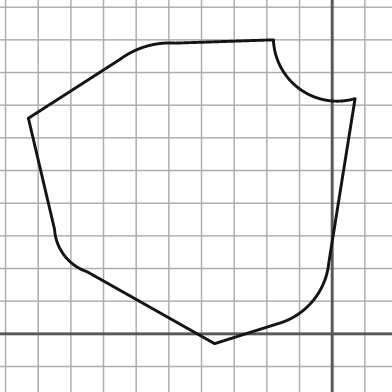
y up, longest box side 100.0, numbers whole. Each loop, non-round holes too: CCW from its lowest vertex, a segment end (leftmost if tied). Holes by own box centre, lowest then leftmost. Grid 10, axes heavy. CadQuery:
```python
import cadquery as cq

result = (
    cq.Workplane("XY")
    .moveTo(-36.0, -3.0)
    .lineTo(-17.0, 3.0)
    .threePointArc((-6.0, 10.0), (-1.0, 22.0))
    .lineTo(7.0, 72.0)
    .threePointArc((-10.0, 75.0), (-18.0, 90.0))
    .lineTo(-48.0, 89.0)
    .threePointArc((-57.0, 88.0), (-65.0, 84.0))
    .lineTo(-93.0, 66.0)
    .lineTo(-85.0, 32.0)
    .threePointArc((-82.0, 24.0), (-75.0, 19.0))
    .close()
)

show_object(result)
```